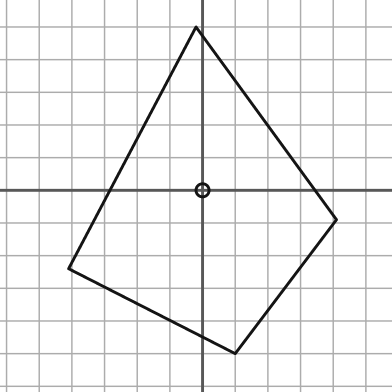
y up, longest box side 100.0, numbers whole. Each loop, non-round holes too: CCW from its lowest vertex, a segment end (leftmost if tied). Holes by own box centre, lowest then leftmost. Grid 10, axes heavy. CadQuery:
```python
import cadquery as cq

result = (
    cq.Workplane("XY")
    .moveTo(10.0, -50.0)
    .lineTo(41.0, -9.0)
    .lineTo(-2.0, 50.0)
    .lineTo(-41.0, -24.0)
    .close()
    .moveTo(0.0, 0.0)
    .circle(2.0)
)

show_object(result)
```